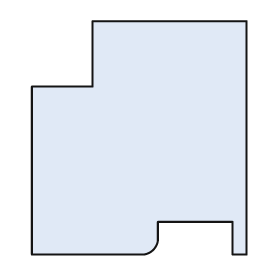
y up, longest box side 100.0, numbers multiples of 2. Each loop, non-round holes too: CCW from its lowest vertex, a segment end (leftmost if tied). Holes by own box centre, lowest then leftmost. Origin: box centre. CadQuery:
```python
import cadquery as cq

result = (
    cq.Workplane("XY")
    .moveTo(-46.0, -50.0)
    .lineTo(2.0, -50.0)
    .threePointArc((6.0, -48.0), (8.0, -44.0))
    .lineTo(8.0, -36.0)
    .lineTo(40.0, -36.0)
    .lineTo(40.0, -50.0)
    .lineTo(46.0, -50.0)
    .lineTo(46.0, 50.0)
    .lineTo(-20.0, 50.0)
    .lineTo(-20.0, 22.0)
    .lineTo(-46.0, 22.0)
    .close()
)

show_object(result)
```